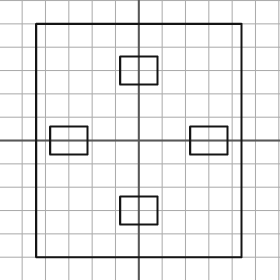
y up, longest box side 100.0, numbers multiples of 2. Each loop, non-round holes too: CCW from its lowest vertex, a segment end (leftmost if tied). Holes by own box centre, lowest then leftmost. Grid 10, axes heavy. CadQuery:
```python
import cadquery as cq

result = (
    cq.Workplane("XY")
    .moveTo(-44.0, -50.0)
    .lineTo(44.0, -50.0)
    .lineTo(44.0, 50.0)
    .lineTo(-44.0, 50.0)
    .close()
    .moveTo(-8.0, -36.0)
    .lineTo(8.0, -36.0)
    .lineTo(8.0, -24.0)
    .lineTo(-8.0, -24.0)
    .close()
    .moveTo(-38.0, -6.0)
    .lineTo(-22.0, -6.0)
    .lineTo(-22.0, 6.0)
    .lineTo(-38.0, 6.0)
    .close()
    .moveTo(22.0, -6.0)
    .lineTo(38.0, -6.0)
    .lineTo(38.0, 6.0)
    .lineTo(22.0, 6.0)
    .close()
    .moveTo(-8.0, 24.0)
    .lineTo(8.0, 24.0)
    .lineTo(8.0, 36.0)
    .lineTo(-8.0, 36.0)
    .close()
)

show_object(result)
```